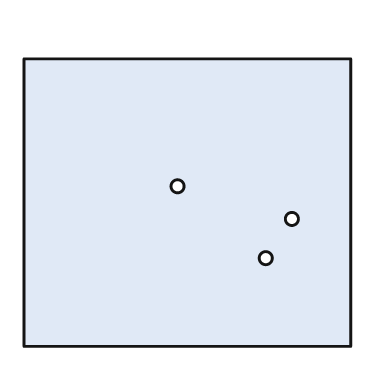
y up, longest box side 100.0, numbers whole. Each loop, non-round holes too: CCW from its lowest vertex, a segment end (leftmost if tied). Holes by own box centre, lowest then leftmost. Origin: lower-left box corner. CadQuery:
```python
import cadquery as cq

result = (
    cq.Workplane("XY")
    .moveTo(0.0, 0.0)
    .lineTo(100.0, 0.0)
    .lineTo(100.0, 88.0)
    .lineTo(0.0, 88.0)
    .close()
    .moveTo(74.0, 27.0)
    .circle(2.0)
    .moveTo(82.0, 39.0)
    .circle(2.0)
    .moveTo(47.0, 49.0)
    .circle(2.0)
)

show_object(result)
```